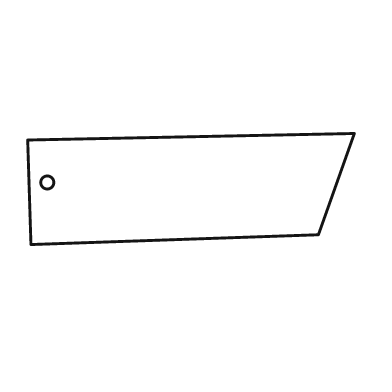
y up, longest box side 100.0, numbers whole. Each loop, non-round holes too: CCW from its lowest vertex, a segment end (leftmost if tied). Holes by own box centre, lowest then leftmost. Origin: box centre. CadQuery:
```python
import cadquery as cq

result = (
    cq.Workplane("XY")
    .moveTo(-49.0, -17.0)
    .lineTo(39.0, -14.0)
    .lineTo(50.0, 17.0)
    .lineTo(-50.0, 15.0)
    .close()
    .moveTo(-44.0, 2.0)
    .circle(2.0)
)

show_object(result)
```